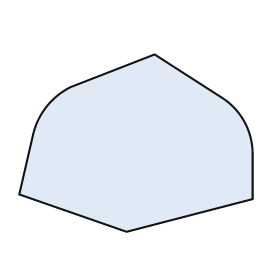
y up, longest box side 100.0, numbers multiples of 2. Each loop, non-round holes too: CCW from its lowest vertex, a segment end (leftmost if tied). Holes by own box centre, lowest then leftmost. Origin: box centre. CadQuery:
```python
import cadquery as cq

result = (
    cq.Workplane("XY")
    .moveTo(-4.0, -38.0)
    .lineTo(50.0, -24.0)
    .lineTo(50.0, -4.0)
    .threePointArc((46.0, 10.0), (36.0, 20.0))
    .lineTo(8.0, 38.0)
    .lineTo(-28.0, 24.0)
    .threePointArc((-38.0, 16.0), (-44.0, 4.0))
    .lineTo(-50.0, -22.0)
    .close()
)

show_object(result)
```